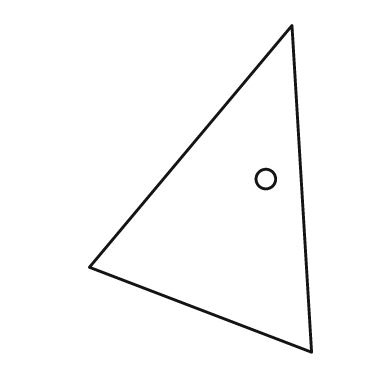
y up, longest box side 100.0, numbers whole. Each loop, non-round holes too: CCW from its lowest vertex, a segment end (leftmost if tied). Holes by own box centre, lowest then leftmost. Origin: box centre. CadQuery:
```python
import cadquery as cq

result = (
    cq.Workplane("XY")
    .moveTo(34.0, -50.0)
    .lineTo(28.0, 50.0)
    .lineTo(-34.0, -24.0)
    .close()
    .moveTo(20.0, 3.0)
    .circle(3.0)
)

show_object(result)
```